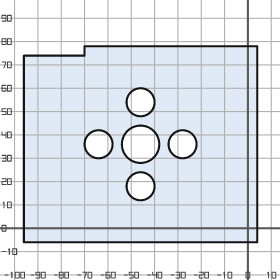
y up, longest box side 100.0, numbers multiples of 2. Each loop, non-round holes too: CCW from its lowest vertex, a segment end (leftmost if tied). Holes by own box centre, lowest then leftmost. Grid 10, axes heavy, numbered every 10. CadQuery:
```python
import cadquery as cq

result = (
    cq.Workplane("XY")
    .moveTo(-96.0, -6.0)
    .lineTo(4.0, -6.0)
    .lineTo(4.0, 78.0)
    .lineTo(-70.0, 78.0)
    .lineTo(-70.0, 74.0)
    .lineTo(-96.0, 74.0)
    .close()
    .moveTo(-46.0, 18.0)
    .circle(6.0)
    .moveTo(-64.0, 36.0)
    .circle(6.0)
    .moveTo(-46.0, 36.0)
    .circle(8.0)
    .moveTo(-28.0, 36.0)
    .circle(6.0)
    .moveTo(-46.0, 54.0)
    .circle(6.0)
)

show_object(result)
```